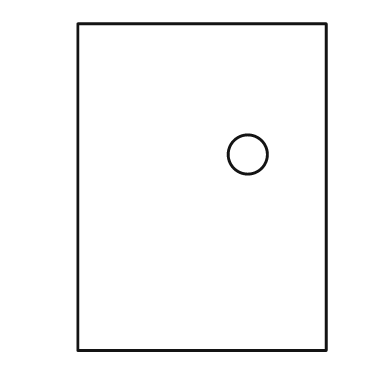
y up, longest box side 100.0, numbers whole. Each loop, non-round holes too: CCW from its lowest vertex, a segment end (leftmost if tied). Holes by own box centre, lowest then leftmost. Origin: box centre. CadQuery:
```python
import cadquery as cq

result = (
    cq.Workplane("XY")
    .moveTo(-38.0, -50.0)
    .lineTo(38.0, -50.0)
    .lineTo(38.0, 50.0)
    .lineTo(-38.0, 50.0)
    .close()
    .moveTo(14.0, 10.0)
    .circle(6.0)
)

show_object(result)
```